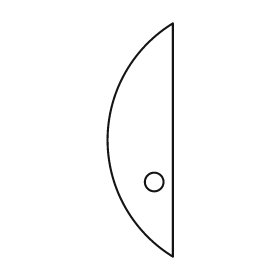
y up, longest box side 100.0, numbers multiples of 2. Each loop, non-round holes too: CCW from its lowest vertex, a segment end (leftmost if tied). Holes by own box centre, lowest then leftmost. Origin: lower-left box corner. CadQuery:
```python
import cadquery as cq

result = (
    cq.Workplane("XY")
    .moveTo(28.0, 0.0)
    .lineTo(28.0, 100.0)
    .threePointArc((0.0, 50.0), (28.0, 0.0))
    .close()
    .moveTo(20.0, 32.0)
    .circle(4.0)
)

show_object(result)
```